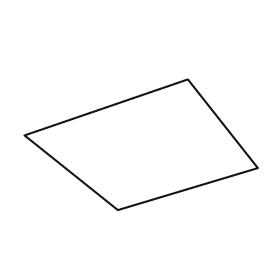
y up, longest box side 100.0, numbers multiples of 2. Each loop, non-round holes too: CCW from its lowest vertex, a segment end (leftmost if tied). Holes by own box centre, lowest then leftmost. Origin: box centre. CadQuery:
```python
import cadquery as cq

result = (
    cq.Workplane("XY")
    .moveTo(-10.0, -28.0)
    .lineTo(50.0, -10.0)
    .lineTo(20.0, 28.0)
    .lineTo(-50.0, 4.0)
    .close()
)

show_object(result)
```